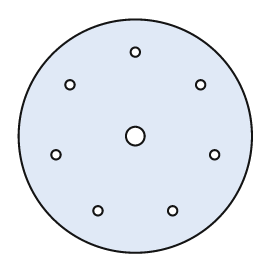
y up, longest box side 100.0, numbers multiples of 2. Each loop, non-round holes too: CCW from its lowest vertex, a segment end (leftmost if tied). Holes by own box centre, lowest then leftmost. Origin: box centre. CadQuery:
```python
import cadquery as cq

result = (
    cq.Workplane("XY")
    .moveTo(0.0, 0.0)
    .circle(50.0)
    .moveTo(-16.0, -32.0)
    .circle(2.0)
    .moveTo(16.0, -32.0)
    .circle(2.0)
    .moveTo(-34.0, -8.0)
    .circle(2.0)
    .moveTo(34.0, -8.0)
    .circle(2.0)
    .moveTo(0.0, 0.0)
    .circle(4.0)
    .moveTo(-28.0, 22.0)
    .circle(2.0)
    .moveTo(28.0, 22.0)
    .circle(2.0)
    .moveTo(0.0, 36.0)
    .circle(2.0)
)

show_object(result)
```